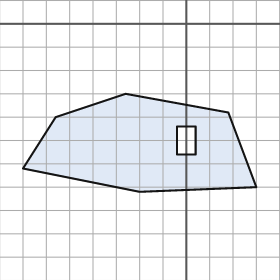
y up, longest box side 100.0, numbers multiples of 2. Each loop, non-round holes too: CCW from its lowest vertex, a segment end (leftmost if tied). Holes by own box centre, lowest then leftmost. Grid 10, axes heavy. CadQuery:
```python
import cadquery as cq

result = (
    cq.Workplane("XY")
    .moveTo(-20.0, -72.0)
    .lineTo(30.0, -70.0)
    .lineTo(18.0, -38.0)
    .lineTo(-26.0, -30.0)
    .lineTo(-56.0, -40.0)
    .lineTo(-70.0, -62.0)
    .close()
    .moveTo(-4.0, -56.0)
    .lineTo(4.0, -56.0)
    .lineTo(4.0, -44.0)
    .lineTo(-4.0, -44.0)
    .close()
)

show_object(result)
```